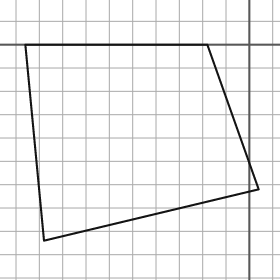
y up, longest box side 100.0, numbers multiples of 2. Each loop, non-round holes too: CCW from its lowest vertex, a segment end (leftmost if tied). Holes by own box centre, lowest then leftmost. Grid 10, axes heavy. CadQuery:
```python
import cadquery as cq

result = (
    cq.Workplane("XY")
    .moveTo(-88.0, -84.0)
    .lineTo(4.0, -62.0)
    .lineTo(-18.0, 0.0)
    .lineTo(-96.0, 0.0)
    .close()
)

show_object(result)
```